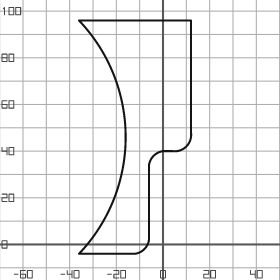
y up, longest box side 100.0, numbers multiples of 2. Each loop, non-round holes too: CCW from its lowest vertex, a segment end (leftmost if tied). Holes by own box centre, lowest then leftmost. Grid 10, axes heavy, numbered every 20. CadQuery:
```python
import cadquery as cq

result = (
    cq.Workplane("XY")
    .moveTo(-36.0, -4.0)
    .lineTo(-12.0, -4.0)
    .threePointArc((-8.0, -2.0), (-6.0, 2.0))
    .lineTo(-6.0, 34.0)
    .threePointArc((-4.0, 38.0), (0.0, 40.0))
    .lineTo(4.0, 40.0)
    .threePointArc((10.0, 42.0), (12.0, 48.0))
    .lineTo(12.0, 96.0)
    .lineTo(-36.0, 96.0)
    .threePointArc((-16.0, 46.0), (-36.0, -4.0))
    .close()
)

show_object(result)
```